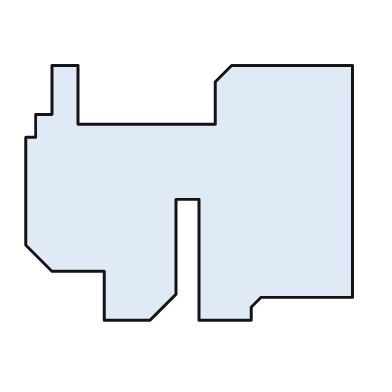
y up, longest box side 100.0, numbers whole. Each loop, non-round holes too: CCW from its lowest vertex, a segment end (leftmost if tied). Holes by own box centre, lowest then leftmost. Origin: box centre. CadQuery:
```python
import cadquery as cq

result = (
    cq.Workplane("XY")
    .moveTo(-26.0, -39.0)
    .lineTo(-12.0, -39.0)
    .lineTo(-4.0, -31.0)
    .lineTo(-4.0, -2.0)
    .lineTo(3.0, -2.0)
    .lineTo(3.0, -39.0)
    .lineTo(19.0, -39.0)
    .lineTo(19.0, -35.0)
    .lineTo(22.0, -32.0)
    .lineTo(50.0, -32.0)
    .lineTo(50.0, 39.0)
    .lineTo(13.0, 39.0)
    .lineTo(8.0, 34.0)
    .lineTo(8.0, 21.0)
    .lineTo(-34.0, 21.0)
    .lineTo(-34.0, 39.0)
    .lineTo(-42.0, 39.0)
    .lineTo(-42.0, 24.0)
    .lineTo(-47.0, 24.0)
    .lineTo(-47.0, 17.0)
    .lineTo(-50.0, 17.0)
    .lineTo(-50.0, -16.0)
    .lineTo(-42.0, -24.0)
    .lineTo(-26.0, -24.0)
    .close()
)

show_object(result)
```